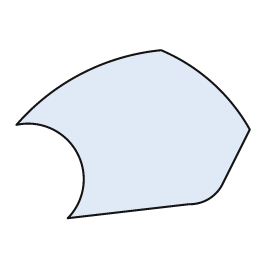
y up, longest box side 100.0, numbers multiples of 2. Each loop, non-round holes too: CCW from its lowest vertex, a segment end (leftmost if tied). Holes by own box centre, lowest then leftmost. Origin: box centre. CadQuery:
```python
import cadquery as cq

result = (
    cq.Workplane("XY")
    .moveTo(-28.0, -36.0)
    .lineTo(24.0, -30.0)
    .threePointArc((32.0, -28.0), (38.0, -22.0))
    .lineTo(50.0, 2.0)
    .threePointArc((34.0, 22.0), (12.0, 36.0))
    .threePointArc((-22.0, 26.0), (-50.0, 4.0))
    .threePointArc((-24.0, -8.0), (-28.0, -36.0))
    .close()
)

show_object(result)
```